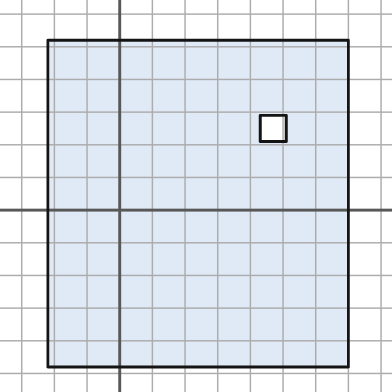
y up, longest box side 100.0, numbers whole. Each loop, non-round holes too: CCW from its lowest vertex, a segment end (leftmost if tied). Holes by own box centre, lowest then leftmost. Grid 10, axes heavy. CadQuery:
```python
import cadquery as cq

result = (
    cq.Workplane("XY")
    .moveTo(-22.0, -48.0)
    .lineTo(70.0, -48.0)
    .lineTo(70.0, 52.0)
    .lineTo(-22.0, 52.0)
    .close()
    .moveTo(43.0, 21.0)
    .lineTo(51.0, 21.0)
    .lineTo(51.0, 29.0)
    .lineTo(43.0, 29.0)
    .close()
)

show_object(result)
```